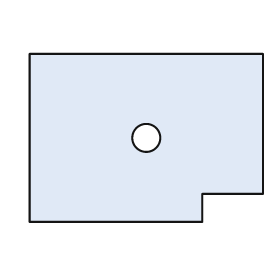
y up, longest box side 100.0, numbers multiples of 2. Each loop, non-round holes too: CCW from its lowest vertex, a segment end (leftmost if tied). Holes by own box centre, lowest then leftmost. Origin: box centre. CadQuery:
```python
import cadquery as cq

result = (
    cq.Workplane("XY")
    .moveTo(-50.0, -36.0)
    .lineTo(24.0, -36.0)
    .lineTo(24.0, -24.0)
    .lineTo(50.0, -24.0)
    .lineTo(50.0, 36.0)
    .lineTo(-50.0, 36.0)
    .close()
    .moveTo(0.0, 0.0)
    .circle(6.0)
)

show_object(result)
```